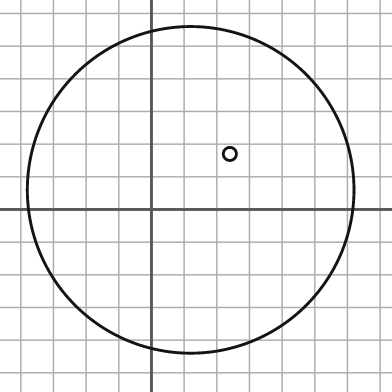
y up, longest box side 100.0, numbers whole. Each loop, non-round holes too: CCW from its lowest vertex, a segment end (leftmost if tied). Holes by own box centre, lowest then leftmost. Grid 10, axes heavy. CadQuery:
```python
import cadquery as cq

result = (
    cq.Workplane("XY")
    .moveTo(12.0, 6.0)
    .circle(50.0)
    .moveTo(24.0, 17.0)
    .circle(2.0)
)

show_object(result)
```